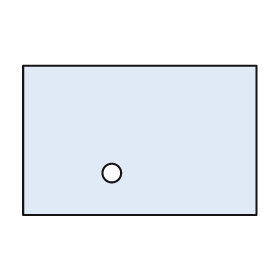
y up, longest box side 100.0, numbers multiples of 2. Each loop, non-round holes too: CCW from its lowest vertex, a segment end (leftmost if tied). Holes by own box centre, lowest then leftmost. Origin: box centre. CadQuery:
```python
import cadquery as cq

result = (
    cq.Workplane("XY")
    .moveTo(-50.0, -32.0)
    .lineTo(50.0, -32.0)
    .lineTo(50.0, 32.0)
    .lineTo(-50.0, 32.0)
    .close()
    .moveTo(-12.0, -14.0)
    .circle(4.0)
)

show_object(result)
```